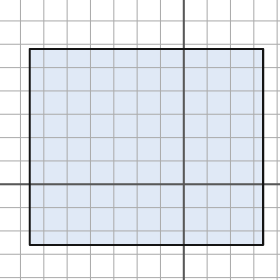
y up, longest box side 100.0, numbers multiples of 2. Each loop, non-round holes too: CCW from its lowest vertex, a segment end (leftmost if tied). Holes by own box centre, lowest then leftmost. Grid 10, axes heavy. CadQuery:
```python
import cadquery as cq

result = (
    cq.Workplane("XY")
    .moveTo(-66.0, -26.0)
    .lineTo(34.0, -26.0)
    .lineTo(34.0, 58.0)
    .lineTo(-66.0, 58.0)
    .close()
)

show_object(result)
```